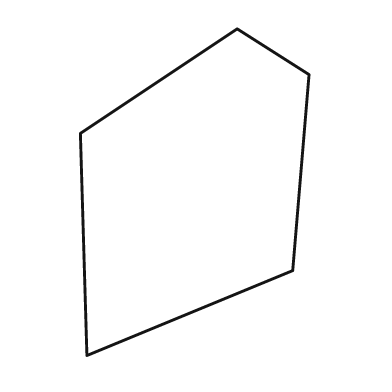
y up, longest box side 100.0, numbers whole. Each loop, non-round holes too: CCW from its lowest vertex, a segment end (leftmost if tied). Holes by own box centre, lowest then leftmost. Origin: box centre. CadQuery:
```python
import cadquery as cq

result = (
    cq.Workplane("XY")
    .moveTo(-33.0, -50.0)
    .lineTo(30.0, -24.0)
    .lineTo(35.0, 36.0)
    .lineTo(13.0, 50.0)
    .lineTo(-35.0, 18.0)
    .close()
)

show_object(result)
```